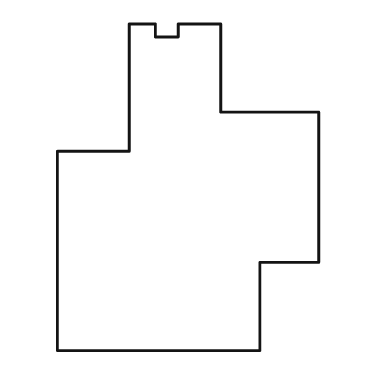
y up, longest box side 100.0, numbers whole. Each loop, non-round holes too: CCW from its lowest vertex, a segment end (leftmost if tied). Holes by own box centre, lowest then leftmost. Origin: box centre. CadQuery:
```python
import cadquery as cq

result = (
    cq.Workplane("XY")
    .moveTo(-40.0, -50.0)
    .lineTo(22.0, -50.0)
    .lineTo(22.0, -23.0)
    .lineTo(40.0, -23.0)
    .lineTo(40.0, 23.0)
    .lineTo(10.0, 23.0)
    .lineTo(10.0, 50.0)
    .lineTo(-3.0, 50.0)
    .lineTo(-3.0, 46.0)
    .lineTo(-10.0, 46.0)
    .lineTo(-10.0, 50.0)
    .lineTo(-18.0, 50.0)
    .lineTo(-18.0, 11.0)
    .lineTo(-40.0, 11.0)
    .close()
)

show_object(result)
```